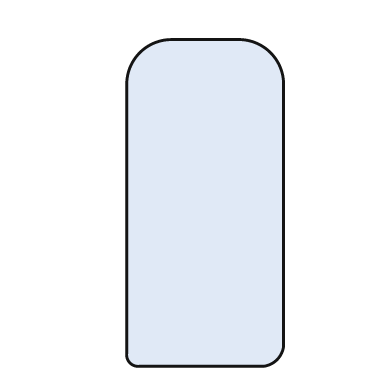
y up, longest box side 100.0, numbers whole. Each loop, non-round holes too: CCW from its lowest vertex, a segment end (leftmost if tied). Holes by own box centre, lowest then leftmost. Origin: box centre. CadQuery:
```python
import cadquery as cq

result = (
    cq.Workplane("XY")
    .moveTo(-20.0, -50.0)
    .lineTo(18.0, -50.0)
    .threePointArc((22.0, -48.0), (24.0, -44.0))
    .lineTo(24.0, 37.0)
    .threePointArc((20.0, 46.0), (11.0, 50.0))
    .lineTo(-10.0, 50.0)
    .threePointArc((-20.0, 46.0), (-24.0, 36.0))
    .lineTo(-24.0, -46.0)
    .threePointArc((-23.0, -49.0), (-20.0, -50.0))
    .close()
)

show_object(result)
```